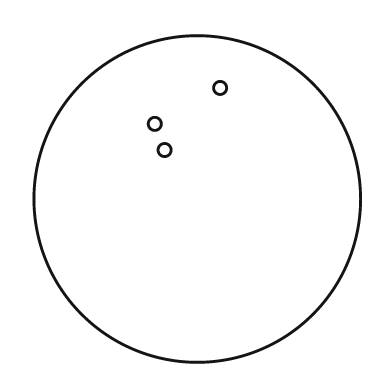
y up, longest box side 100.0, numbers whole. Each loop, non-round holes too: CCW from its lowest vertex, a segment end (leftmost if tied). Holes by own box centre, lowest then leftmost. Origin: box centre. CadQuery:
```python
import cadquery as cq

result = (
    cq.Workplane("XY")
    .moveTo(0.0, 0.0)
    .circle(50.0)
    .moveTo(-10.0, 15.0)
    .circle(2.0)
    .moveTo(-13.0, 23.0)
    .circle(2.0)
    .moveTo(7.0, 34.0)
    .circle(2.0)
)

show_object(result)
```